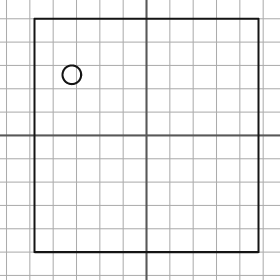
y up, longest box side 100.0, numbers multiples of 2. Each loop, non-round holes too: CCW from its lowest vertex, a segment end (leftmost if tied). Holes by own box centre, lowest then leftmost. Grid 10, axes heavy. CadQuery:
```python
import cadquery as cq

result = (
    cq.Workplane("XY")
    .moveTo(-48.0, -50.0)
    .lineTo(48.0, -50.0)
    .lineTo(48.0, 50.0)
    .lineTo(-48.0, 50.0)
    .close()
    .moveTo(-32.0, 26.0)
    .circle(4.0)
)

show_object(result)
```